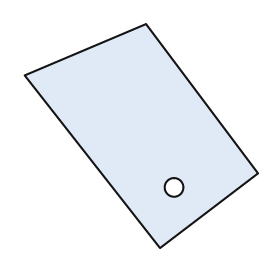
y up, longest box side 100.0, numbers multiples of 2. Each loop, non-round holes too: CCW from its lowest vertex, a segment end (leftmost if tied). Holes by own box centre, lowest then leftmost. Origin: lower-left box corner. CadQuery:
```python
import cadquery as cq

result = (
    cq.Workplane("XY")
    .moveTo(58.0, 0.0)
    .lineTo(100.0, 32.0)
    .lineTo(52.0, 96.0)
    .lineTo(0.0, 74.0)
    .close()
    .moveTo(64.0, 26.0)
    .circle(4.0)
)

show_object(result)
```